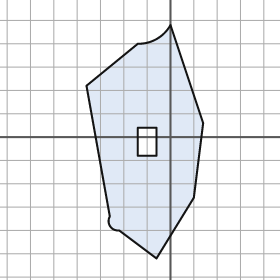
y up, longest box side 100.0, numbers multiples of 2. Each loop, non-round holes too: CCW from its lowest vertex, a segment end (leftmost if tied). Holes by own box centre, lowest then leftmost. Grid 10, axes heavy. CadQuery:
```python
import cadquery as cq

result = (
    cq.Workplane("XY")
    .moveTo(-6.0, -52.0)
    .lineTo(10.0, -26.0)
    .lineTo(14.0, 6.0)
    .lineTo(0.0, 48.0)
    .threePointArc((-6.0, 42.0), (-14.0, 40.0))
    .lineTo(-36.0, 22.0)
    .lineTo(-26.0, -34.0)
    .threePointArc((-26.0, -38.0), (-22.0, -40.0))
    .close()
    .moveTo(-14.0, -8.0)
    .lineTo(-6.0, -8.0)
    .lineTo(-6.0, 4.0)
    .lineTo(-14.0, 4.0)
    .close()
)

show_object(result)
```